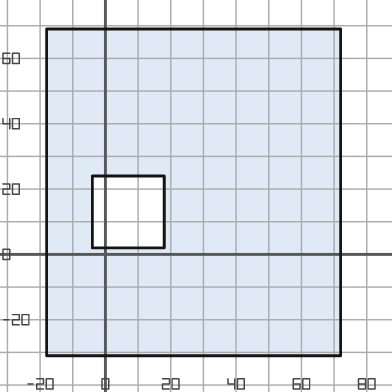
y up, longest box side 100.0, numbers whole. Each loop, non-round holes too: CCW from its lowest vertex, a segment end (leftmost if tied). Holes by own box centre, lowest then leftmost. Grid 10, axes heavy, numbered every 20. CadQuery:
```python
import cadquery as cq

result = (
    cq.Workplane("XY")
    .moveTo(-18.0, -31.0)
    .lineTo(72.0, -31.0)
    .lineTo(72.0, 69.0)
    .lineTo(-18.0, 69.0)
    .close()
    .moveTo(-4.0, 2.0)
    .lineTo(18.0, 2.0)
    .lineTo(18.0, 24.0)
    .lineTo(-4.0, 24.0)
    .close()
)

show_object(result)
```